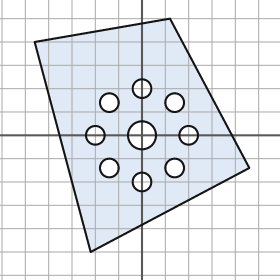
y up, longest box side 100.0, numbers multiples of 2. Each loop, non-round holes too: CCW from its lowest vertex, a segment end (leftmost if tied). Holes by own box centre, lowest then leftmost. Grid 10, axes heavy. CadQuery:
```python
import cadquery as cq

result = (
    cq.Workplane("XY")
    .moveTo(-22.0, -50.0)
    .lineTo(46.0, -14.0)
    .lineTo(12.0, 50.0)
    .lineTo(-46.0, 40.0)
    .close()
    .moveTo(0.0, -20.0)
    .circle(4.0)
    .moveTo(-14.0, -14.0)
    .circle(4.0)
    .moveTo(14.0, -14.0)
    .circle(4.0)
    .moveTo(-20.0, 0.0)
    .circle(4.0)
    .moveTo(0.0, 0.0)
    .circle(6.0)
    .moveTo(20.0, 0.0)
    .circle(4.0)
    .moveTo(-14.0, 14.0)
    .circle(4.0)
    .moveTo(14.0, 14.0)
    .circle(4.0)
    .moveTo(0.0, 20.0)
    .circle(4.0)
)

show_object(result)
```